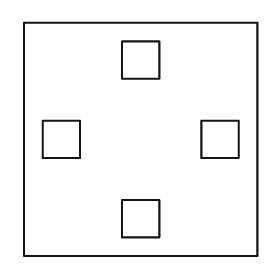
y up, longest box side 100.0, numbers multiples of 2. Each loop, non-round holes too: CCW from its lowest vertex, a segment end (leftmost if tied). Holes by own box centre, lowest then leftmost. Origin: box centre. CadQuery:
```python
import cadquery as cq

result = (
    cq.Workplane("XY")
    .moveTo(-50.0, -50.0)
    .lineTo(50.0, -50.0)
    .lineTo(50.0, 50.0)
    .lineTo(-50.0, 50.0)
    .close()
    .moveTo(-8.0, -42.0)
    .lineTo(8.0, -42.0)
    .lineTo(8.0, -26.0)
    .lineTo(-8.0, -26.0)
    .close()
    .moveTo(-42.0, -8.0)
    .lineTo(-26.0, -8.0)
    .lineTo(-26.0, 8.0)
    .lineTo(-42.0, 8.0)
    .close()
    .moveTo(26.0, -8.0)
    .lineTo(42.0, -8.0)
    .lineTo(42.0, 8.0)
    .lineTo(26.0, 8.0)
    .close()
    .moveTo(-8.0, 26.0)
    .lineTo(8.0, 26.0)
    .lineTo(8.0, 42.0)
    .lineTo(-8.0, 42.0)
    .close()
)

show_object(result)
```